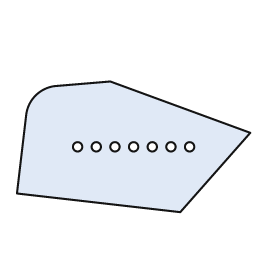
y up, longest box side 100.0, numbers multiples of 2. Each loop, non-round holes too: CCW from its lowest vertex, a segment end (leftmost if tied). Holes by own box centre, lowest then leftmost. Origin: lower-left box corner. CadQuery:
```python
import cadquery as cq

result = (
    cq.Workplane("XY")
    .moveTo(70.0, 0.0)
    .lineTo(100.0, 34.0)
    .lineTo(40.0, 56.0)
    .lineTo(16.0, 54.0)
    .threePointArc((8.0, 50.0), (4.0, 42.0))
    .lineTo(0.0, 8.0)
    .close()
    .moveTo(26.0, 28.0)
    .circle(2.0)
    .moveTo(34.0, 28.0)
    .circle(2.0)
    .moveTo(42.0, 28.0)
    .circle(2.0)
    .moveTo(50.0, 28.0)
    .circle(2.0)
    .moveTo(58.0, 28.0)
    .circle(2.0)
    .moveTo(66.0, 28.0)
    .circle(2.0)
    .moveTo(74.0, 28.0)
    .circle(2.0)
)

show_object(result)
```